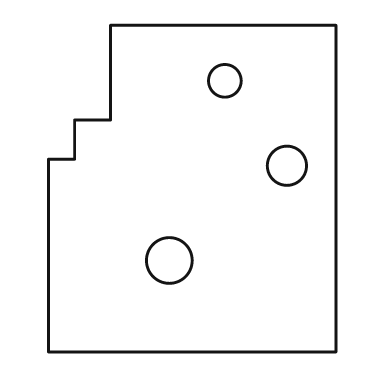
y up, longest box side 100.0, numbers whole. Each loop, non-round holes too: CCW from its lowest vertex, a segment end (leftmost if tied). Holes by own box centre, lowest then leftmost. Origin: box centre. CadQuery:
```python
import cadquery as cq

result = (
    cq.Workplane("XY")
    .moveTo(-44.0, -50.0)
    .lineTo(44.0, -50.0)
    .lineTo(44.0, 50.0)
    .lineTo(-25.0, 50.0)
    .lineTo(-25.0, 21.0)
    .lineTo(-36.0, 21.0)
    .lineTo(-36.0, 9.0)
    .lineTo(-44.0, 9.0)
    .close()
    .moveTo(-7.0, -22.0)
    .circle(7.0)
    .moveTo(29.0, 7.0)
    .circle(6.0)
    .moveTo(10.0, 33.0)
    .circle(5.0)
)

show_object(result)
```